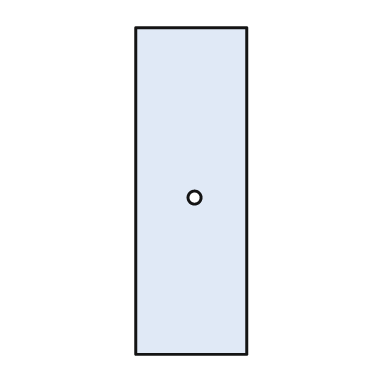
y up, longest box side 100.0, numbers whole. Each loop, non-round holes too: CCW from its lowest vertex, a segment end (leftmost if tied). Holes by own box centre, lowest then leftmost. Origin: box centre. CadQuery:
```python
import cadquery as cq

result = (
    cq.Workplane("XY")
    .moveTo(-17.0, -50.0)
    .lineTo(17.0, -50.0)
    .lineTo(17.0, 50.0)
    .lineTo(-17.0, 50.0)
    .close()
    .moveTo(1.0, -2.0)
    .circle(2.0)
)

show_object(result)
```